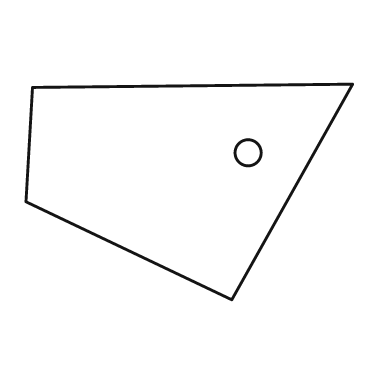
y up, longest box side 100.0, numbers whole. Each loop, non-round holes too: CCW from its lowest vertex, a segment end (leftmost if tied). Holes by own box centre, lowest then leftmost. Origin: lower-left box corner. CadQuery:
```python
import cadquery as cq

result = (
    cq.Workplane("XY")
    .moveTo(63.0, 0.0)
    .lineTo(100.0, 66.0)
    .lineTo(2.0, 65.0)
    .lineTo(0.0, 30.0)
    .close()
    .moveTo(68.0, 45.0)
    .circle(4.0)
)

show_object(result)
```